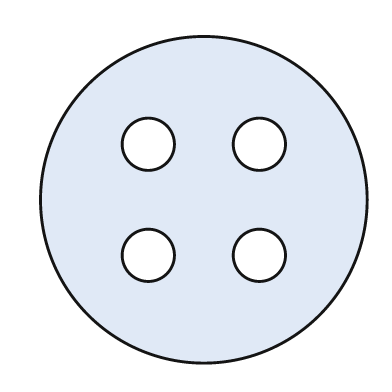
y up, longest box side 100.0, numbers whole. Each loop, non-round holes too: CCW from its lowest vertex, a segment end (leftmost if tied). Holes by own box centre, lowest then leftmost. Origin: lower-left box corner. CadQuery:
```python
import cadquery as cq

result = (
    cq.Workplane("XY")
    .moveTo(50.0, 50.0)
    .circle(50.0)
    .moveTo(33.0, 33.0)
    .circle(8.0)
    .moveTo(67.0, 33.0)
    .circle(8.0)
    .moveTo(33.0, 67.0)
    .circle(8.0)
    .moveTo(67.0, 67.0)
    .circle(8.0)
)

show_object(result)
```